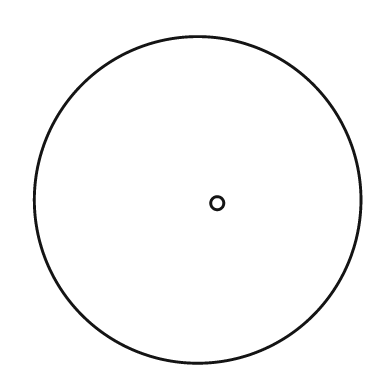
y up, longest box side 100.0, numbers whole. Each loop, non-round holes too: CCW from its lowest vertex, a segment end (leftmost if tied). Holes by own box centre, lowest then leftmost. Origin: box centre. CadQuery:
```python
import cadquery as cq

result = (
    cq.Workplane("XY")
    .moveTo(0.0, 0.0)
    .circle(50.0)
    .moveTo(6.0, -1.0)
    .circle(2.0)
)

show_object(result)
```